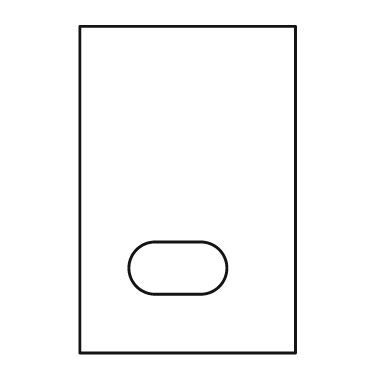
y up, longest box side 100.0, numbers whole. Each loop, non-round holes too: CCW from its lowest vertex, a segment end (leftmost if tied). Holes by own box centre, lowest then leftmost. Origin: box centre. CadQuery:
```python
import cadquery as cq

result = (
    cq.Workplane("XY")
    .moveTo(-33.0, -50.0)
    .lineTo(33.0, -50.0)
    .lineTo(33.0, 50.0)
    .lineTo(-33.0, 50.0)
    .close()
    .moveTo(-10.0, -32.0)
    .lineTo(4.0, -32.0)
    .threePointArc((12.0, -24.0), (4.0, -16.0))
    .lineTo(-10.0, -16.0)
    .threePointArc((-18.0, -24.0), (-10.0, -32.0))
    .close()
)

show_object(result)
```